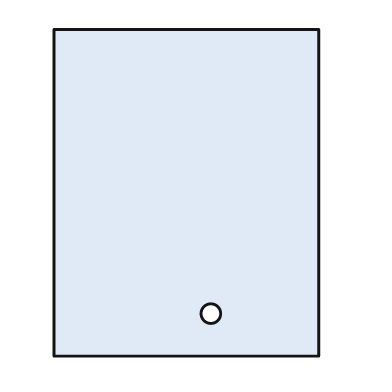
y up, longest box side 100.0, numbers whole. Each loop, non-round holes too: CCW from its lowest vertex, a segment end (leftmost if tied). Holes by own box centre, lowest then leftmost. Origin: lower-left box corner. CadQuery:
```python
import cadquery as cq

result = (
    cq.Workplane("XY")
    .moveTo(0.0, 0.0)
    .lineTo(81.0, 0.0)
    .lineTo(81.0, 100.0)
    .lineTo(0.0, 100.0)
    .close()
    .moveTo(48.0, 13.0)
    .circle(3.0)
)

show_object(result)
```